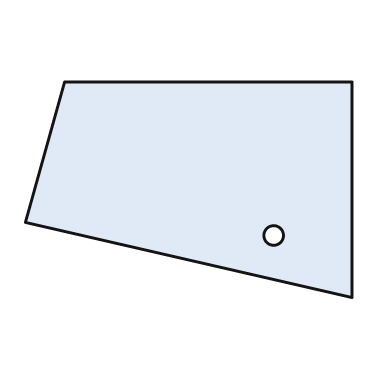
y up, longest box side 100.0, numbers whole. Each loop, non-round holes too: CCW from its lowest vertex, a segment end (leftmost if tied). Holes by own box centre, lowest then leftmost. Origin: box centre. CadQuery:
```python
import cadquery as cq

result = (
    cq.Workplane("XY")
    .moveTo(50.0, -33.0)
    .lineTo(50.0, 33.0)
    .lineTo(-38.0, 33.0)
    .lineTo(-50.0, -10.0)
    .close()
    .moveTo(26.0, -14.0)
    .circle(3.0)
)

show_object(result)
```